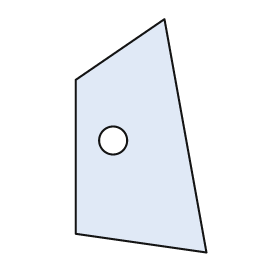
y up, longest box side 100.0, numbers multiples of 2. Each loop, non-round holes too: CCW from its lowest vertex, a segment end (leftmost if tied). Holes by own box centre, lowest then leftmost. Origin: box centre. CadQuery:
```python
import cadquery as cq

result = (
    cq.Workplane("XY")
    .moveTo(28.0, -50.0)
    .lineTo(10.0, 50.0)
    .lineTo(-28.0, 24.0)
    .lineTo(-28.0, -42.0)
    .close()
    .moveTo(-12.0, -2.0)
    .circle(6.0)
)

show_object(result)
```